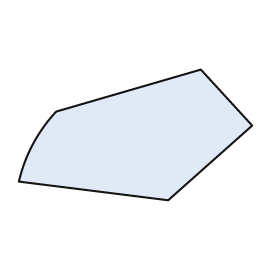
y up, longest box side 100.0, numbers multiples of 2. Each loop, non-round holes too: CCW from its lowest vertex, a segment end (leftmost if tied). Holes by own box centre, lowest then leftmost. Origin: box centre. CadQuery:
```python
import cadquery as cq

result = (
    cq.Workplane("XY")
    .moveTo(14.0, -28.0)
    .lineTo(50.0, 4.0)
    .lineTo(28.0, 28.0)
    .lineTo(-34.0, 10.0)
    .threePointArc((-44.0, -4.0), (-50.0, -20.0))
    .close()
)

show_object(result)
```